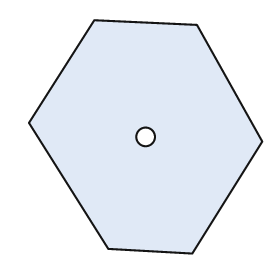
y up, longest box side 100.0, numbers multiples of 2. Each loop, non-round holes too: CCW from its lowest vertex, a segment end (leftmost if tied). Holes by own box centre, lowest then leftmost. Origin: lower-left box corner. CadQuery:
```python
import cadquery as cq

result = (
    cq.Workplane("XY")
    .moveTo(70.0, 0.0)
    .lineTo(100.0, 48.0)
    .lineTo(72.0, 98.0)
    .lineTo(28.0, 100.0)
    .lineTo(0.0, 56.0)
    .lineTo(34.0, 2.0)
    .close()
    .moveTo(50.0, 50.0)
    .circle(4.0)
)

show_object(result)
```